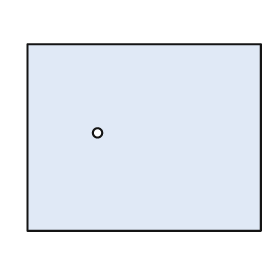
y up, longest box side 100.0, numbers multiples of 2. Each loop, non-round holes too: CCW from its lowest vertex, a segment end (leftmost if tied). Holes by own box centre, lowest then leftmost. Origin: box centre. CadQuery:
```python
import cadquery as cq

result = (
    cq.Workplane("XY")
    .moveTo(-50.0, -40.0)
    .lineTo(50.0, -40.0)
    .lineTo(50.0, 40.0)
    .lineTo(-50.0, 40.0)
    .close()
    .moveTo(-20.0, 2.0)
    .circle(2.0)
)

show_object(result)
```